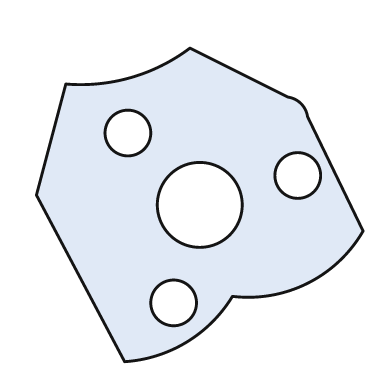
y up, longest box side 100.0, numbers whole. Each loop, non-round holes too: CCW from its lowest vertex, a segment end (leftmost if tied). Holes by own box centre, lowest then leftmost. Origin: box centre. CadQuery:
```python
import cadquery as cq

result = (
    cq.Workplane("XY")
    .moveTo(-23.0, -48.0)
    .threePointArc((-4.0, -42.0), (10.0, -28.0))
    .threePointArc((33.0, -24.0), (50.0, -8.0))
    .lineTo(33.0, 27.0)
    .threePointArc((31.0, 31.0), (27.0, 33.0))
    .lineTo(-3.0, 48.0)
    .threePointArc((-21.0, 39.0), (-41.0, 37.0))
    .lineTo(-50.0, 3.0)
    .close()
    .moveTo(-8.0, -30.0)
    .circle(7.0)
    .moveTo(0.0, 0.0)
    .circle(13.0)
    .moveTo(30.0, 9.0)
    .circle(7.0)
    .moveTo(-22.0, 22.0)
    .circle(7.0)
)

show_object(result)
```